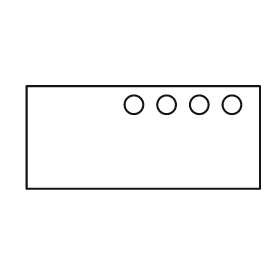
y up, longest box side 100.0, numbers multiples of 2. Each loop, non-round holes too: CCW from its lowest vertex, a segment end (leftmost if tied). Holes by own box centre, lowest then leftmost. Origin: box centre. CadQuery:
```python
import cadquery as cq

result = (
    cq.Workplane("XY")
    .moveTo(-50.0, -22.0)
    .lineTo(50.0, -22.0)
    .lineTo(50.0, 22.0)
    .lineTo(-50.0, 22.0)
    .close()
    .moveTo(-4.0, 14.0)
    .circle(4.0)
    .moveTo(10.0, 14.0)
    .circle(4.0)
    .moveTo(24.0, 14.0)
    .circle(4.0)
    .moveTo(38.0, 14.0)
    .circle(4.0)
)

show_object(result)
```